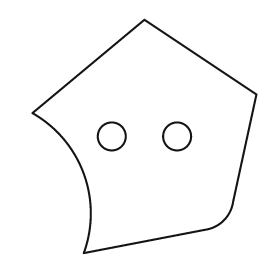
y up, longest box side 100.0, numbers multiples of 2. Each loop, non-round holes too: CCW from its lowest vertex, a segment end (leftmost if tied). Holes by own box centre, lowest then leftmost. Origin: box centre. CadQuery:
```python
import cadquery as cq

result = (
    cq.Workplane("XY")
    .moveTo(-26.0, -50.0)
    .lineTo(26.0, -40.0)
    .threePointArc((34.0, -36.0), (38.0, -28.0))
    .lineTo(48.0, 18.0)
    .lineTo(0.0, 50.0)
    .lineTo(-48.0, 10.0)
    .threePointArc((-26.0, -16.0), (-26.0, -50.0))
    .close()
    .moveTo(-14.0, 0.0)
    .circle(6.0)
    .moveTo(14.0, 0.0)
    .circle(6.0)
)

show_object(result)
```